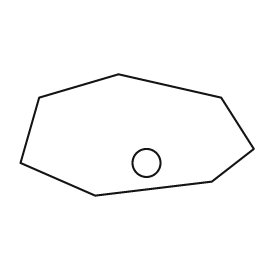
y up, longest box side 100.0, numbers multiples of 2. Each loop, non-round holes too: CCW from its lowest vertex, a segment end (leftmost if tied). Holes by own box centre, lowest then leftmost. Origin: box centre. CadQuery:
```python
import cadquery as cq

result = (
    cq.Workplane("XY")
    .moveTo(-18.0, -26.0)
    .lineTo(32.0, -20.0)
    .lineTo(50.0, -6.0)
    .lineTo(36.0, 16.0)
    .lineTo(-8.0, 26.0)
    .lineTo(-42.0, 16.0)
    .lineTo(-50.0, -12.0)
    .close()
    .moveTo(4.0, -12.0)
    .circle(6.0)
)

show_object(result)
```